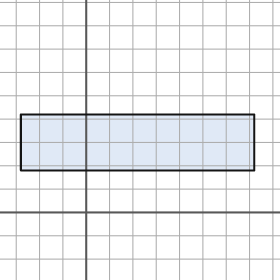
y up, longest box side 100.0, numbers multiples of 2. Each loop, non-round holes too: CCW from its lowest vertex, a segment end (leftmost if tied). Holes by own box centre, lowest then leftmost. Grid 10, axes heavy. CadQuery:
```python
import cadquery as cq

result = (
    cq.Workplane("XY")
    .moveTo(-28.0, 18.0)
    .lineTo(72.0, 18.0)
    .lineTo(72.0, 42.0)
    .lineTo(-28.0, 42.0)
    .close()
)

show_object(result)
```